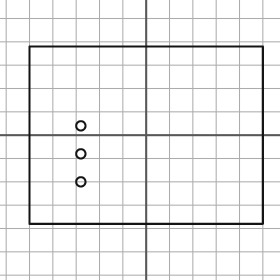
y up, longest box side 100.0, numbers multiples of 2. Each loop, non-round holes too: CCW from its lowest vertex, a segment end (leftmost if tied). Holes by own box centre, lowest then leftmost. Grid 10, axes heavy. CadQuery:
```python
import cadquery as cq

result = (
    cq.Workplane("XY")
    .moveTo(-50.0, -38.0)
    .lineTo(50.0, -38.0)
    .lineTo(50.0, 38.0)
    .lineTo(-50.0, 38.0)
    .close()
    .moveTo(-28.0, -20.0)
    .circle(2.0)
    .moveTo(-28.0, -8.0)
    .circle(2.0)
    .moveTo(-28.0, 4.0)
    .circle(2.0)
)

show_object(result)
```